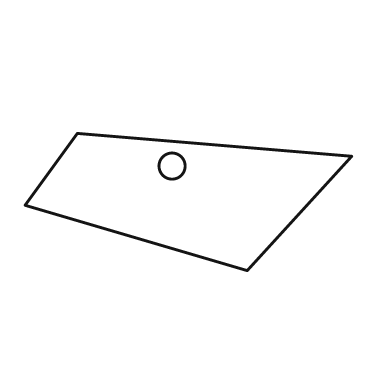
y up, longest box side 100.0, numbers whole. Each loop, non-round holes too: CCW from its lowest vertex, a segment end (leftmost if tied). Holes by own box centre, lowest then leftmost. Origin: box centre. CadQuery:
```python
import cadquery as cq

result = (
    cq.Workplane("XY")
    .moveTo(18.0, -21.0)
    .lineTo(50.0, 14.0)
    .lineTo(-34.0, 21.0)
    .lineTo(-50.0, -1.0)
    .close()
    .moveTo(-5.0, 11.0)
    .circle(4.0)
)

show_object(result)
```